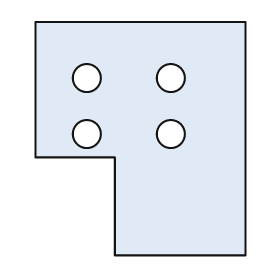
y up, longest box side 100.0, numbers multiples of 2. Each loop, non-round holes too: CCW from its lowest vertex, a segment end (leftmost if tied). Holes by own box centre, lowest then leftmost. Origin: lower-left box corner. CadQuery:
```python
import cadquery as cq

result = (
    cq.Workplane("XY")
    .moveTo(34.0, 0.0)
    .lineTo(90.0, 0.0)
    .lineTo(90.0, 100.0)
    .lineTo(0.0, 100.0)
    .lineTo(0.0, 42.0)
    .lineTo(34.0, 42.0)
    .close()
    .moveTo(22.0, 52.0)
    .circle(6.0)
    .moveTo(58.0, 52.0)
    .circle(6.0)
    .moveTo(22.0, 76.0)
    .circle(6.0)
    .moveTo(58.0, 76.0)
    .circle(6.0)
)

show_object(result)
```